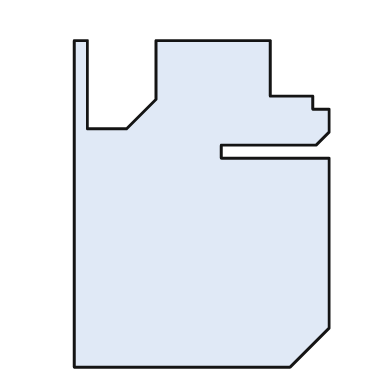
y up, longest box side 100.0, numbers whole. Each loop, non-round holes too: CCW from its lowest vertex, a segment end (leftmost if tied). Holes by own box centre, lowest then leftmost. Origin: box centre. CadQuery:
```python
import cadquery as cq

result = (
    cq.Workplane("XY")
    .moveTo(-39.0, -50.0)
    .lineTo(27.0, -50.0)
    .lineTo(39.0, -38.0)
    .lineTo(39.0, 14.0)
    .lineTo(6.0, 14.0)
    .lineTo(6.0, 18.0)
    .lineTo(35.0, 18.0)
    .lineTo(39.0, 22.0)
    .lineTo(39.0, 29.0)
    .lineTo(34.0, 29.0)
    .lineTo(34.0, 33.0)
    .lineTo(21.0, 33.0)
    .lineTo(21.0, 50.0)
    .lineTo(-14.0, 50.0)
    .lineTo(-14.0, 32.0)
    .lineTo(-23.0, 23.0)
    .lineTo(-35.0, 23.0)
    .lineTo(-35.0, 50.0)
    .lineTo(-39.0, 50.0)
    .close()
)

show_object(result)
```